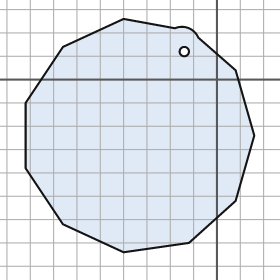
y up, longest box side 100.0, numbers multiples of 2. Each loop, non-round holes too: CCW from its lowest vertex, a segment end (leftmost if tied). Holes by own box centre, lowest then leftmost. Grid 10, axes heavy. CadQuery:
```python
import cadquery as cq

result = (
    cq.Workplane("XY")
    .moveTo(-40.0, -74.0)
    .lineTo(-12.0, -70.0)
    .lineTo(8.0, -52.0)
    .lineTo(16.0, -24.0)
    .lineTo(8.0, 4.0)
    .lineTo(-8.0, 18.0)
    .threePointArc((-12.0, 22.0), (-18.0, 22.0))
    .lineTo(-40.0, 26.0)
    .lineTo(-66.0, 14.0)
    .lineTo(-82.0, -10.0)
    .lineTo(-82.0, -38.0)
    .lineTo(-66.0, -62.0)
    .close()
    .moveTo(-14.0, 12.0)
    .circle(2.0)
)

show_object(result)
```